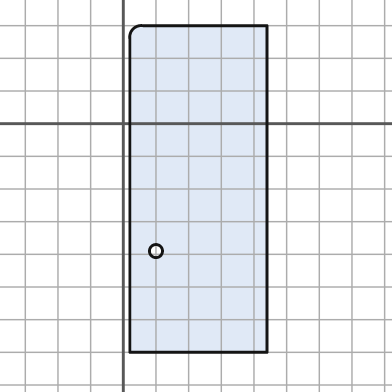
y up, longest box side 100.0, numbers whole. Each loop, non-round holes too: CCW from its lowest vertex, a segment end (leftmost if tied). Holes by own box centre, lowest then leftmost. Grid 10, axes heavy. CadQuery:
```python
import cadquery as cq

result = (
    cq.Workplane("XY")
    .moveTo(2.0, -70.0)
    .lineTo(44.0, -70.0)
    .lineTo(44.0, 30.0)
    .lineTo(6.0, 30.0)
    .threePointArc((3.0, 29.0), (2.0, 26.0))
    .close()
    .moveTo(10.0, -39.0)
    .circle(2.0)
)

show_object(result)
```